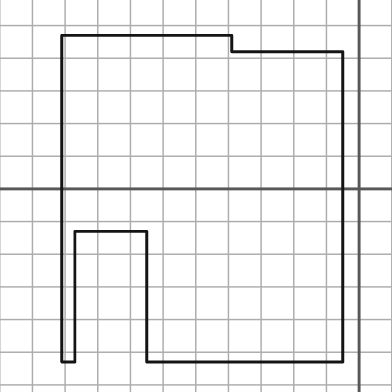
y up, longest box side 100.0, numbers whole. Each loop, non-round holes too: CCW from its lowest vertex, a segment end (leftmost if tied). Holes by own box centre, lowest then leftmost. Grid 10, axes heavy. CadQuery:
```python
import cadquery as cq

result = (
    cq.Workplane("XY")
    .moveTo(-91.0, -53.0)
    .lineTo(-87.0, -53.0)
    .lineTo(-87.0, -13.0)
    .lineTo(-65.0, -13.0)
    .lineTo(-65.0, -53.0)
    .lineTo(-5.0, -53.0)
    .lineTo(-5.0, 42.0)
    .lineTo(-39.0, 42.0)
    .lineTo(-39.0, 47.0)
    .lineTo(-91.0, 47.0)
    .close()
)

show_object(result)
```